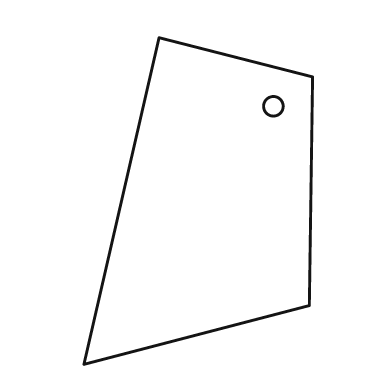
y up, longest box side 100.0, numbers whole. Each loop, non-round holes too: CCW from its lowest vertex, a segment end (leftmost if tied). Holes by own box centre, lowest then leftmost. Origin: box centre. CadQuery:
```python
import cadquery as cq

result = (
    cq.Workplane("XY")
    .moveTo(-35.0, -50.0)
    .lineTo(34.0, -32.0)
    .lineTo(35.0, 38.0)
    .lineTo(-12.0, 50.0)
    .close()
    .moveTo(23.0, 29.0)
    .circle(3.0)
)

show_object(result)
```